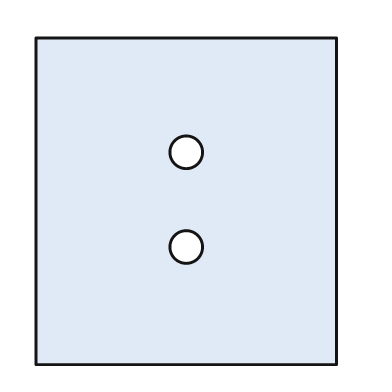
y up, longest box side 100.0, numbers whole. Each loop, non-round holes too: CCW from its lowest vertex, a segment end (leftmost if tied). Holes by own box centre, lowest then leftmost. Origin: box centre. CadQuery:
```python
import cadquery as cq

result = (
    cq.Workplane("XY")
    .moveTo(-46.0, -50.0)
    .lineTo(46.0, -50.0)
    .lineTo(46.0, 50.0)
    .lineTo(-46.0, 50.0)
    .close()
    .moveTo(0.0, -14.0)
    .circle(5.0)
    .moveTo(0.0, 15.0)
    .circle(5.0)
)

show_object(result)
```